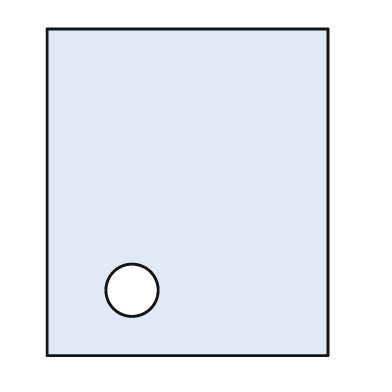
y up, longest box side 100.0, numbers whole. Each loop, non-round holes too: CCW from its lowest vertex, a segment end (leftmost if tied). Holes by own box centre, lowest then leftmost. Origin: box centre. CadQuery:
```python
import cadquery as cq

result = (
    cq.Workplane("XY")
    .moveTo(-43.0, -50.0)
    .lineTo(43.0, -50.0)
    .lineTo(43.0, 50.0)
    .lineTo(-43.0, 50.0)
    .close()
    .moveTo(-17.0, -30.0)
    .circle(8.0)
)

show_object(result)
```